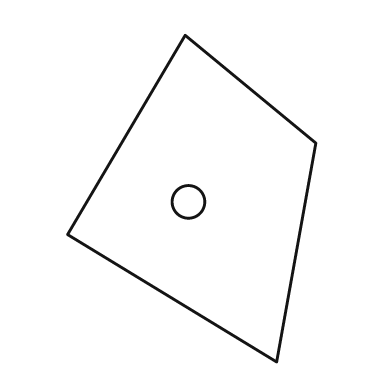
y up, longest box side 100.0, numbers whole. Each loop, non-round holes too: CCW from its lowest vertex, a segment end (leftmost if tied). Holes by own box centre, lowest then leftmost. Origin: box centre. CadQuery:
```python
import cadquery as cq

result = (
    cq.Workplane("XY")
    .moveTo(26.0, -50.0)
    .lineTo(38.0, 17.0)
    .lineTo(-2.0, 50.0)
    .lineTo(-38.0, -11.0)
    .close()
    .moveTo(-1.0, -1.0)
    .circle(5.0)
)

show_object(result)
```